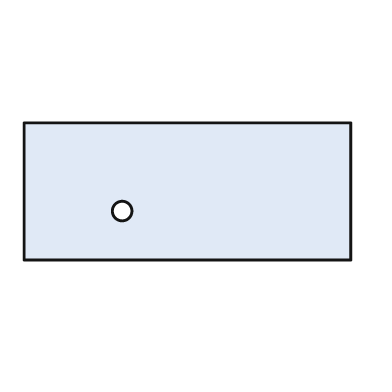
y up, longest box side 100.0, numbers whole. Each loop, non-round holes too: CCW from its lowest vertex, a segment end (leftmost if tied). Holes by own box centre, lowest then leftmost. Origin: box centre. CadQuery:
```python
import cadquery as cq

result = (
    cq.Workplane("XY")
    .moveTo(-50.0, -21.0)
    .lineTo(50.0, -21.0)
    .lineTo(50.0, 21.0)
    .lineTo(-50.0, 21.0)
    .close()
    .moveTo(-20.0, -6.0)
    .circle(3.0)
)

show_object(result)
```